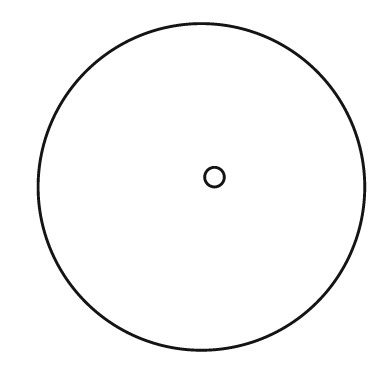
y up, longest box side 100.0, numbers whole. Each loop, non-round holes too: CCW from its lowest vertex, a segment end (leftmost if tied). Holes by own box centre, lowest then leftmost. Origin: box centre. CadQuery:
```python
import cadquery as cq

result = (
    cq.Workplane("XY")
    .moveTo(0.0, 0.0)
    .circle(50.0)
    .moveTo(4.0, 3.0)
    .circle(3.0)
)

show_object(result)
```